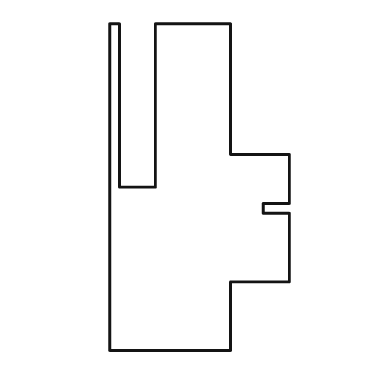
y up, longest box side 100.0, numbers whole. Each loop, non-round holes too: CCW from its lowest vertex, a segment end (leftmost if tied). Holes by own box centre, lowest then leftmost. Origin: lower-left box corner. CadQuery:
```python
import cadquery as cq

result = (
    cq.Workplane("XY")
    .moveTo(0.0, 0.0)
    .lineTo(37.0, 0.0)
    .lineTo(37.0, 21.0)
    .lineTo(55.0, 21.0)
    .lineTo(55.0, 42.0)
    .lineTo(47.0, 42.0)
    .lineTo(47.0, 45.0)
    .lineTo(55.0, 45.0)
    .lineTo(55.0, 60.0)
    .lineTo(37.0, 60.0)
    .lineTo(37.0, 100.0)
    .lineTo(14.0, 100.0)
    .lineTo(14.0, 50.0)
    .lineTo(3.0, 50.0)
    .lineTo(3.0, 100.0)
    .lineTo(0.0, 100.0)
    .close()
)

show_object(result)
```